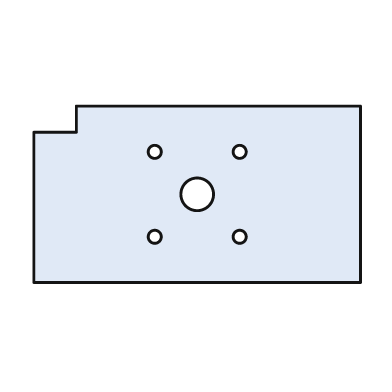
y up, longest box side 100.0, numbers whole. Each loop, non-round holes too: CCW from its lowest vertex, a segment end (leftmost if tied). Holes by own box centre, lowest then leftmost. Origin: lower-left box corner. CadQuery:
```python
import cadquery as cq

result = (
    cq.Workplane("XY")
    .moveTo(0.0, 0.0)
    .lineTo(100.0, 0.0)
    .lineTo(100.0, 54.0)
    .lineTo(13.0, 54.0)
    .lineTo(13.0, 46.0)
    .lineTo(0.0, 46.0)
    .close()
    .moveTo(37.0, 14.0)
    .circle(2.0)
    .moveTo(63.0, 14.0)
    .circle(2.0)
    .moveTo(50.0, 27.0)
    .circle(5.0)
    .moveTo(37.0, 40.0)
    .circle(2.0)
    .moveTo(63.0, 40.0)
    .circle(2.0)
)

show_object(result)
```